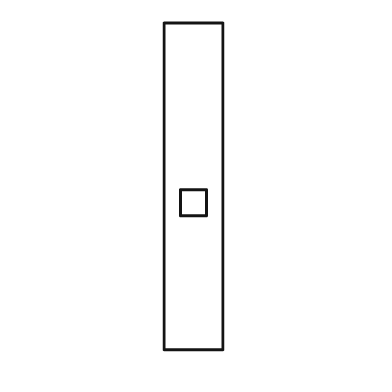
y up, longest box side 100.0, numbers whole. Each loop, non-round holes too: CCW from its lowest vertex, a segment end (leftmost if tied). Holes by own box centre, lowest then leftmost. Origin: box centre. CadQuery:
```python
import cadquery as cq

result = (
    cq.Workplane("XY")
    .moveTo(-9.0, -50.0)
    .lineTo(9.0, -50.0)
    .lineTo(9.0, 50.0)
    .lineTo(-9.0, 50.0)
    .close()
    .moveTo(-4.0, -9.0)
    .lineTo(4.0, -9.0)
    .lineTo(4.0, -1.0)
    .lineTo(-4.0, -1.0)
    .close()
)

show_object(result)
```